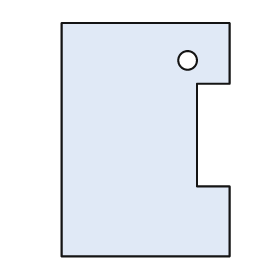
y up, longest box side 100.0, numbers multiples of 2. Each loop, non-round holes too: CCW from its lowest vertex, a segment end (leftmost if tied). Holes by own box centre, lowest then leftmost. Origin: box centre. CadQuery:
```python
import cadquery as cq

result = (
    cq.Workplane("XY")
    .moveTo(-36.0, -50.0)
    .lineTo(36.0, -50.0)
    .lineTo(36.0, -20.0)
    .lineTo(22.0, -20.0)
    .lineTo(22.0, 24.0)
    .lineTo(36.0, 24.0)
    .lineTo(36.0, 50.0)
    .lineTo(-36.0, 50.0)
    .close()
    .moveTo(18.0, 34.0)
    .circle(4.0)
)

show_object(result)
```